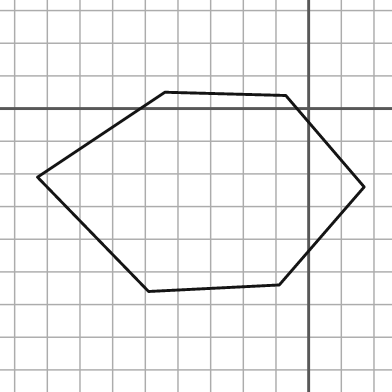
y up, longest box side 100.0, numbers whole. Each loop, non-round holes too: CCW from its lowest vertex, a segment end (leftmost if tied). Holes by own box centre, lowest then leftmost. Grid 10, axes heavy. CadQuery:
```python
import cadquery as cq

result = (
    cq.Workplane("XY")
    .moveTo(-49.0, -56.0)
    .lineTo(-9.0, -54.0)
    .lineTo(17.0, -24.0)
    .lineTo(-7.0, 4.0)
    .lineTo(-44.0, 5.0)
    .lineTo(-83.0, -21.0)
    .close()
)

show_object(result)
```